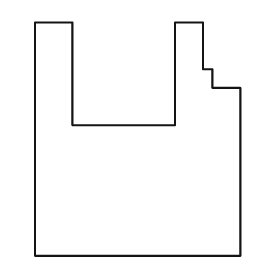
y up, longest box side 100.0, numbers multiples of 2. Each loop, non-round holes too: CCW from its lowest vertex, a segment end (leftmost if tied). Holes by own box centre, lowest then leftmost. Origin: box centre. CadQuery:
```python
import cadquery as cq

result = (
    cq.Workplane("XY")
    .moveTo(-44.0, -50.0)
    .lineTo(44.0, -50.0)
    .lineTo(44.0, 22.0)
    .lineTo(32.0, 22.0)
    .lineTo(32.0, 30.0)
    .lineTo(28.0, 30.0)
    .lineTo(28.0, 50.0)
    .lineTo(16.0, 50.0)
    .lineTo(16.0, 6.0)
    .lineTo(-28.0, 6.0)
    .lineTo(-28.0, 50.0)
    .lineTo(-44.0, 50.0)
    .close()
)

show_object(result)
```